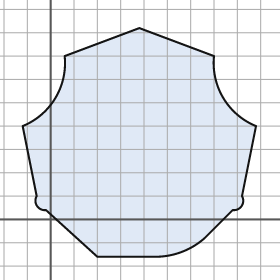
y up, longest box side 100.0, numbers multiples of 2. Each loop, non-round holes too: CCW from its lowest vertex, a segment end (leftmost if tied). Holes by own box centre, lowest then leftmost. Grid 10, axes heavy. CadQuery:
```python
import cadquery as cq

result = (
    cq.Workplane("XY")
    .moveTo(20.0, -16.0)
    .lineTo(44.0, -16.0)
    .threePointArc((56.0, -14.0), (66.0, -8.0))
    .lineTo(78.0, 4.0)
    .threePointArc((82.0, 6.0), (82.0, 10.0))
    .lineTo(88.0, 40.0)
    .threePointArc((74.0, 52.0), (70.0, 70.0))
    .lineTo(38.0, 82.0)
    .lineTo(6.0, 70.0)
    .threePointArc((2.0, 52.0), (-12.0, 40.0))
    .lineTo(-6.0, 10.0)
    .threePointArc((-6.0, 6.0), (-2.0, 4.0))
    .close()
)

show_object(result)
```